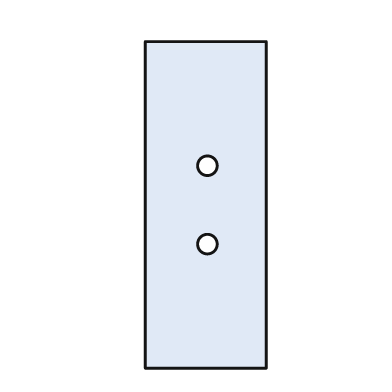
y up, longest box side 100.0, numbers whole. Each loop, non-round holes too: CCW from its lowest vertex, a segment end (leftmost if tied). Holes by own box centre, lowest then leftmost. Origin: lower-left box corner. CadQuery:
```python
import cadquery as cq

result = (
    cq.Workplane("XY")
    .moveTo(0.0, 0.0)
    .lineTo(37.0, 0.0)
    .lineTo(37.0, 100.0)
    .lineTo(0.0, 100.0)
    .close()
    .moveTo(19.0, 38.0)
    .circle(3.0)
    .moveTo(19.0, 62.0)
    .circle(3.0)
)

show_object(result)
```